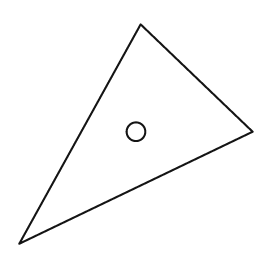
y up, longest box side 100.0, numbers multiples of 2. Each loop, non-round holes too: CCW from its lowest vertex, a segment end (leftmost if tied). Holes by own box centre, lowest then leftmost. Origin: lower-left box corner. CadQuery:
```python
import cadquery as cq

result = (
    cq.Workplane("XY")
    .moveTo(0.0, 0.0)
    .lineTo(100.0, 48.0)
    .lineTo(52.0, 94.0)
    .close()
    .moveTo(50.0, 48.0)
    .circle(4.0)
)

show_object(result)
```